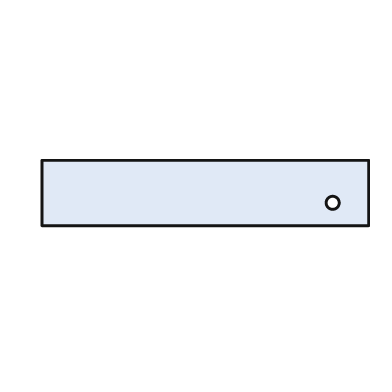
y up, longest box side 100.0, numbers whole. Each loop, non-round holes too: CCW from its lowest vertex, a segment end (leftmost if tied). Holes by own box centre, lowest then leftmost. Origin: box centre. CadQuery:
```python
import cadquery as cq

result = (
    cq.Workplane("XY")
    .moveTo(-50.0, -10.0)
    .lineTo(50.0, -10.0)
    .lineTo(50.0, 10.0)
    .lineTo(-50.0, 10.0)
    .close()
    .moveTo(39.0, -3.0)
    .circle(2.0)
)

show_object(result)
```